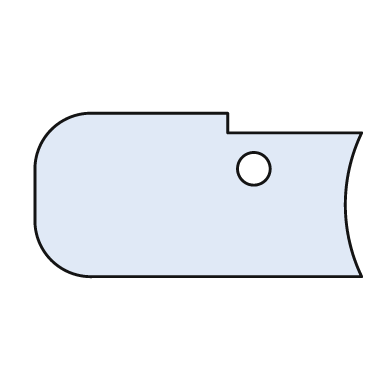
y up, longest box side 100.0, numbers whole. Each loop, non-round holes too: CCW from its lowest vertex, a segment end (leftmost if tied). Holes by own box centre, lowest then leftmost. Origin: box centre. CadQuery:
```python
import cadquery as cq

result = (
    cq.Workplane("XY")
    .moveTo(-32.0, -25.0)
    .lineTo(50.0, -25.0)
    .threePointArc((45.0, -3.0), (50.0, 19.0))
    .lineTo(9.0, 19.0)
    .lineTo(9.0, 25.0)
    .lineTo(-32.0, 25.0)
    .threePointArc((-45.0, 20.0), (-50.0, 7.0))
    .lineTo(-50.0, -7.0)
    .threePointArc((-45.0, -20.0), (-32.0, -25.0))
    .close()
    .moveTo(17.0, 8.0)
    .circle(5.0)
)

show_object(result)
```